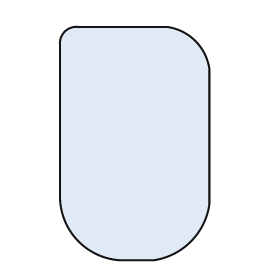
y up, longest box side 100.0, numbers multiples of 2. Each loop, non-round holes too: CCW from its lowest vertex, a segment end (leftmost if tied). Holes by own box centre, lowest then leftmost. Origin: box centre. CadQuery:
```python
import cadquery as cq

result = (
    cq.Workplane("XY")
    .moveTo(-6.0, -50.0)
    .lineTo(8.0, -50.0)
    .threePointArc((24.0, -42.0), (32.0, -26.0))
    .lineTo(32.0, 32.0)
    .threePointArc((26.0, 44.0), (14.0, 50.0))
    .lineTo(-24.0, 50.0)
    .threePointArc((-30.0, 48.0), (-32.0, 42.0))
    .lineTo(-32.0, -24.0)
    .threePointArc((-24.0, -42.0), (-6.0, -50.0))
    .close()
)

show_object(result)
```